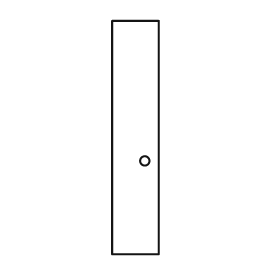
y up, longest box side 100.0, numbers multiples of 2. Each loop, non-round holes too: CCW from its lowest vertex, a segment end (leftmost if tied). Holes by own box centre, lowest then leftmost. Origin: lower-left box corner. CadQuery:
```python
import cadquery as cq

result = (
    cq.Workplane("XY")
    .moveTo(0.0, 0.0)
    .lineTo(20.0, 0.0)
    .lineTo(20.0, 100.0)
    .lineTo(0.0, 100.0)
    .close()
    .moveTo(14.0, 40.0)
    .circle(2.0)
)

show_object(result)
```